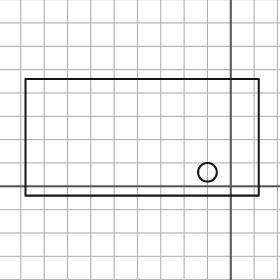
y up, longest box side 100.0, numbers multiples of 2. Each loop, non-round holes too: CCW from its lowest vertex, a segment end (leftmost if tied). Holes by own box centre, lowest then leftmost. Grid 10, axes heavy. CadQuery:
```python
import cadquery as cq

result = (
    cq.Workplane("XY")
    .moveTo(-88.0, -4.0)
    .lineTo(12.0, -4.0)
    .lineTo(12.0, 46.0)
    .lineTo(-88.0, 46.0)
    .close()
    .moveTo(-10.0, 6.0)
    .circle(4.0)
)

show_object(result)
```